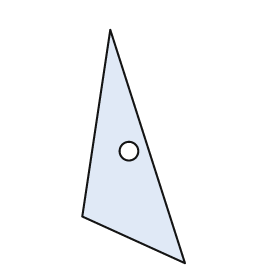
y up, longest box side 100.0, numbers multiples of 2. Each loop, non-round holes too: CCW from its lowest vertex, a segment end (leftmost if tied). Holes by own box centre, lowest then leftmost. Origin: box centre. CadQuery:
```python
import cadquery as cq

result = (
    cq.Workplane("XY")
    .moveTo(22.0, -50.0)
    .lineTo(-10.0, 50.0)
    .lineTo(-22.0, -30.0)
    .close()
    .moveTo(-2.0, -2.0)
    .circle(4.0)
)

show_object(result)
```